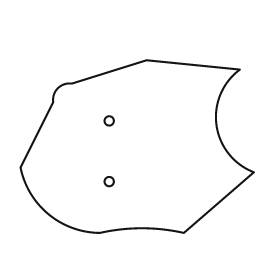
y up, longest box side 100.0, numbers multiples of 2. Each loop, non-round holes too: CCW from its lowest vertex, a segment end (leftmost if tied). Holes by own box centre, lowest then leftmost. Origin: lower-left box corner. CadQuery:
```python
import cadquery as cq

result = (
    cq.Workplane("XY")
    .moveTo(34.0, 0.0)
    .threePointArc((52.0, 2.0), (70.0, 0.0))
    .lineTo(100.0, 26.0)
    .threePointArc((84.0, 46.0), (94.0, 70.0))
    .lineTo(54.0, 74.0)
    .lineTo(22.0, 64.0)
    .threePointArc((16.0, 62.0), (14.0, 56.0))
    .lineTo(0.0, 28.0)
    .threePointArc((12.0, 8.0), (34.0, 0.0))
    .close()
    .moveTo(38.0, 22.0)
    .circle(2.0)
    .moveTo(38.0, 48.0)
    .circle(2.0)
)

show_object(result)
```